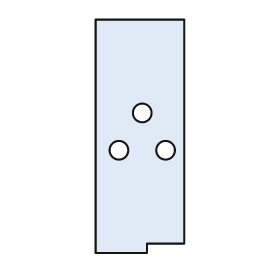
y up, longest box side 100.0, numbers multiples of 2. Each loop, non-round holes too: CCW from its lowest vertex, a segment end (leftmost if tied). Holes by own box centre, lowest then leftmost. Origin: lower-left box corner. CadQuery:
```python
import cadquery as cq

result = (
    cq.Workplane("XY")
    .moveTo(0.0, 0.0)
    .lineTo(22.0, 0.0)
    .lineTo(22.0, 4.0)
    .lineTo(38.0, 4.0)
    .lineTo(38.0, 100.0)
    .lineTo(0.0, 100.0)
    .close()
    .moveTo(10.0, 44.0)
    .circle(4.0)
    .moveTo(30.0, 44.0)
    .circle(4.0)
    .moveTo(20.0, 60.0)
    .circle(4.0)
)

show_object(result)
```